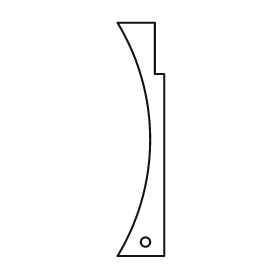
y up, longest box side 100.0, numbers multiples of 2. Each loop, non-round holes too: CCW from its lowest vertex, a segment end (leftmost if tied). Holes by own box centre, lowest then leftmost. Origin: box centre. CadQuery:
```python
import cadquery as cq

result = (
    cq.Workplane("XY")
    .moveTo(-10.0, -50.0)
    .lineTo(10.0, -50.0)
    .lineTo(10.0, 28.0)
    .lineTo(6.0, 28.0)
    .lineTo(6.0, 50.0)
    .lineTo(-10.0, 50.0)
    .threePointArc((4.0, 0.0), (-10.0, -50.0))
    .close()
    .moveTo(2.0, -44.0)
    .circle(2.0)
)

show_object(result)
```